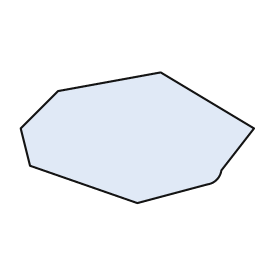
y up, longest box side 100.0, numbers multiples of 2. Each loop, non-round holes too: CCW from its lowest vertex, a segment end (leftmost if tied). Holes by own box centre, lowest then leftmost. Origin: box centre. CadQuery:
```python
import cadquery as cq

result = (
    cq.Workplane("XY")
    .moveTo(0.0, -28.0)
    .lineTo(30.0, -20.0)
    .threePointArc((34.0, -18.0), (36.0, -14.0))
    .lineTo(50.0, 4.0)
    .lineTo(10.0, 28.0)
    .lineTo(-34.0, 20.0)
    .lineTo(-50.0, 4.0)
    .lineTo(-46.0, -12.0)
    .close()
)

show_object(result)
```